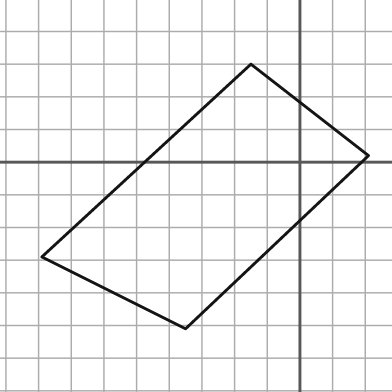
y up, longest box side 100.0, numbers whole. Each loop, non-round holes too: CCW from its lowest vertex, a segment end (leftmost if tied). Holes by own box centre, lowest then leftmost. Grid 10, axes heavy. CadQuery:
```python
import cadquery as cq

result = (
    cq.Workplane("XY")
    .moveTo(-35.0, -51.0)
    .lineTo(21.0, 2.0)
    .lineTo(-15.0, 30.0)
    .lineTo(-79.0, -29.0)
    .close()
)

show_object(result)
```